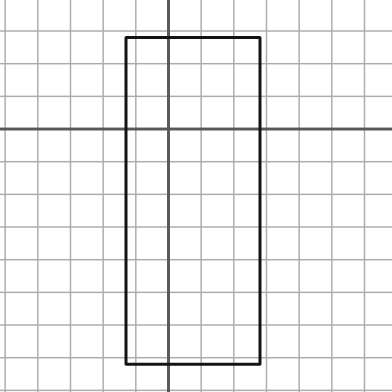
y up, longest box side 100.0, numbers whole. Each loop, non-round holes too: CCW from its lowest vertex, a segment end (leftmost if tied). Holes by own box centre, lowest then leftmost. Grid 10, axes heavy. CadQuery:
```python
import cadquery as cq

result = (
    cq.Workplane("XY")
    .moveTo(-13.0, -72.0)
    .lineTo(28.0, -72.0)
    .lineTo(28.0, 28.0)
    .lineTo(-13.0, 28.0)
    .close()
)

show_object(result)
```